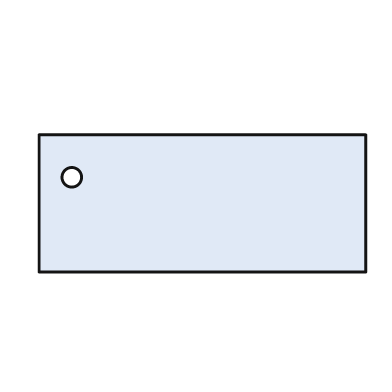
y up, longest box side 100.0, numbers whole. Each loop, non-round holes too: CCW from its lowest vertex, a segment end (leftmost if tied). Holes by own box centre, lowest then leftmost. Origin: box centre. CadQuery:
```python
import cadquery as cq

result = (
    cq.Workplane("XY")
    .moveTo(-50.0, -21.0)
    .lineTo(50.0, -21.0)
    .lineTo(50.0, 21.0)
    .lineTo(-50.0, 21.0)
    .close()
    .moveTo(-40.0, 8.0)
    .circle(3.0)
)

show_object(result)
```